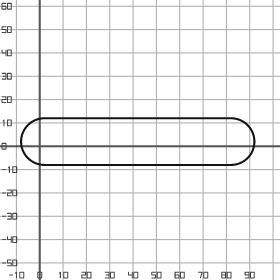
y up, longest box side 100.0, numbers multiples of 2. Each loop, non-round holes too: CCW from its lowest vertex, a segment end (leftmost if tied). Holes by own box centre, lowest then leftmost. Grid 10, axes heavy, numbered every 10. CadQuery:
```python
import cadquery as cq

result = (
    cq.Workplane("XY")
    .moveTo(2.0, -8.0)
    .lineTo(82.0, -8.0)
    .threePointArc((92.0, 2.0), (82.0, 12.0))
    .lineTo(2.0, 12.0)
    .threePointArc((-8.0, 2.0), (2.0, -8.0))
    .close()
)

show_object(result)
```